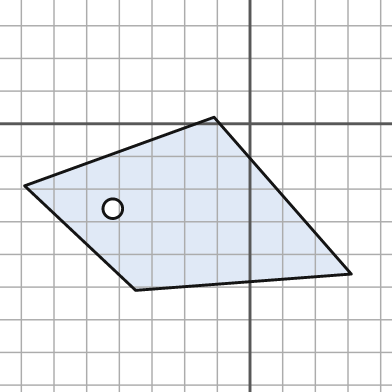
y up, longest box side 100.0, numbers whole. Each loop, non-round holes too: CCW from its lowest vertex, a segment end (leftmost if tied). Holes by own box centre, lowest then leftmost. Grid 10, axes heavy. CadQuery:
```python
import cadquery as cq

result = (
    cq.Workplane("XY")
    .moveTo(-35.0, -51.0)
    .lineTo(31.0, -46.0)
    .lineTo(-11.0, 2.0)
    .lineTo(-69.0, -19.0)
    .close()
    .moveTo(-42.0, -26.0)
    .circle(3.0)
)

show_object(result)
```